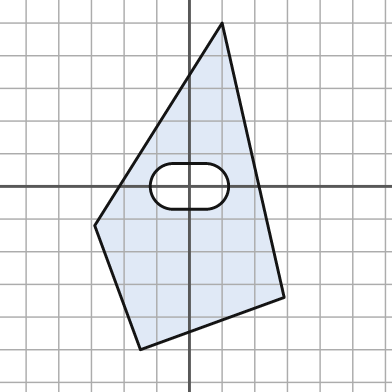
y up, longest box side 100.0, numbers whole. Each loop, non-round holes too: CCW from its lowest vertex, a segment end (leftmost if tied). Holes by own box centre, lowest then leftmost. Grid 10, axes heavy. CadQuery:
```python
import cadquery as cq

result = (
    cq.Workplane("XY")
    .moveTo(-15.0, -50.0)
    .lineTo(29.0, -34.0)
    .lineTo(10.0, 50.0)
    .lineTo(-29.0, -12.0)
    .close()
    .moveTo(-5.0, -7.0)
    .lineTo(5.0, -7.0)
    .threePointArc((12.0, 0.0), (5.0, 7.0))
    .lineTo(-5.0, 7.0)
    .threePointArc((-12.0, 0.0), (-5.0, -7.0))
    .close()
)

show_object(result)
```